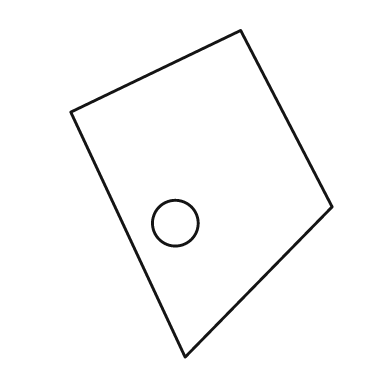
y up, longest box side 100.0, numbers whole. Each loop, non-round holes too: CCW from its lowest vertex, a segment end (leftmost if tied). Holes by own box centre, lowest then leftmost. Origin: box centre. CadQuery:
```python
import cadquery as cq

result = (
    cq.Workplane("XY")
    .moveTo(-5.0, -50.0)
    .lineTo(40.0, -4.0)
    .lineTo(12.0, 50.0)
    .lineTo(-40.0, 25.0)
    .close()
    .moveTo(-8.0, -9.0)
    .circle(7.0)
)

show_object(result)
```